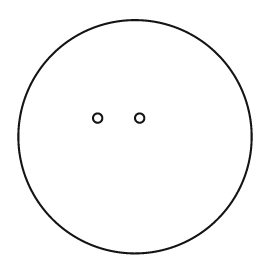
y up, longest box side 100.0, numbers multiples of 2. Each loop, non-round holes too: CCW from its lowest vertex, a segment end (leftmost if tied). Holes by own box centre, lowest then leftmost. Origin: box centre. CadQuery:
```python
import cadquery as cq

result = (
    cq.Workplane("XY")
    .moveTo(0.0, 0.0)
    .circle(50.0)
    .moveTo(-16.0, 8.0)
    .circle(2.0)
    .moveTo(2.0, 8.0)
    .circle(2.0)
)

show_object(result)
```